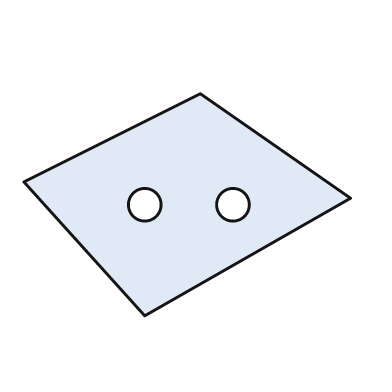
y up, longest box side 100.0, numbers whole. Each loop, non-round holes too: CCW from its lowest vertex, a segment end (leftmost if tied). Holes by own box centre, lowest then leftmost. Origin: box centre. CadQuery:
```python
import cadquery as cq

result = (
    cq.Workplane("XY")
    .moveTo(-13.0, -34.0)
    .lineTo(50.0, 2.0)
    .lineTo(4.0, 34.0)
    .lineTo(-50.0, 7.0)
    .close()
    .moveTo(-13.0, 0.0)
    .circle(5.0)
    .moveTo(14.0, 0.0)
    .circle(5.0)
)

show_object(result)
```